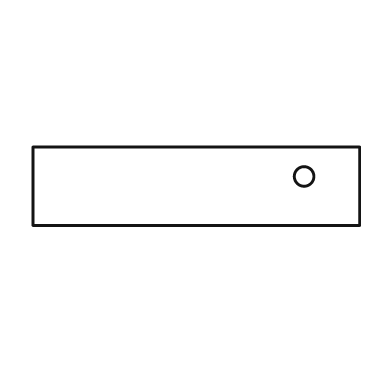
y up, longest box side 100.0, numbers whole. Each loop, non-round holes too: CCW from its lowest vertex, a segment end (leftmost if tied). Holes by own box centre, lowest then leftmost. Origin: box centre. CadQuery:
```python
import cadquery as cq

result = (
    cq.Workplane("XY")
    .moveTo(-50.0, -12.0)
    .lineTo(50.0, -12.0)
    .lineTo(50.0, 12.0)
    .lineTo(-50.0, 12.0)
    .close()
    .moveTo(33.0, 3.0)
    .circle(3.0)
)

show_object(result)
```